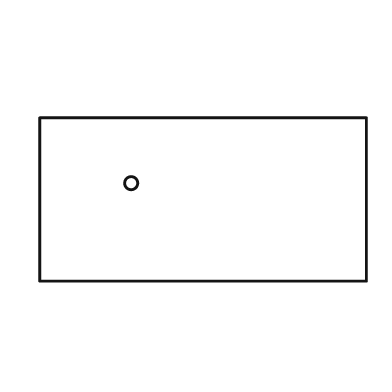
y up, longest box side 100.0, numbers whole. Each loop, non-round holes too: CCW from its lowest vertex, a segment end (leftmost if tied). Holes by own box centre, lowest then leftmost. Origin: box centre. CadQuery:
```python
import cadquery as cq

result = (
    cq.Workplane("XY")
    .moveTo(-50.0, -25.0)
    .lineTo(50.0, -25.0)
    .lineTo(50.0, 25.0)
    .lineTo(-50.0, 25.0)
    .close()
    .moveTo(-22.0, 5.0)
    .circle(2.0)
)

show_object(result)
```